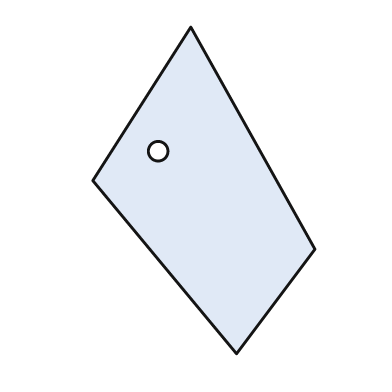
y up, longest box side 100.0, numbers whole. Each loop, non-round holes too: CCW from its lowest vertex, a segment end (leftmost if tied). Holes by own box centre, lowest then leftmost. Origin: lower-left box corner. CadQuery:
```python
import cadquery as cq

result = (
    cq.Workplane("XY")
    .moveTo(44.0, 0.0)
    .lineTo(68.0, 32.0)
    .lineTo(30.0, 100.0)
    .lineTo(0.0, 53.0)
    .close()
    .moveTo(20.0, 62.0)
    .circle(3.0)
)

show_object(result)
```